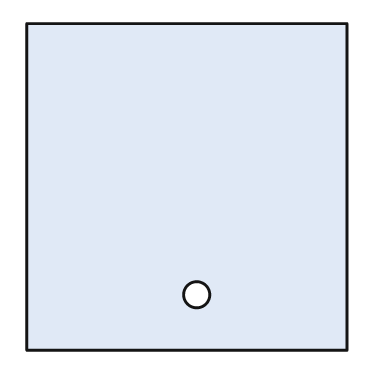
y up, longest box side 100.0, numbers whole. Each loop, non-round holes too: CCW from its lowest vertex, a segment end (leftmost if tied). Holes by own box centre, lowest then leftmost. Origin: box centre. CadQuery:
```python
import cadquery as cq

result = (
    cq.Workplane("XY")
    .moveTo(-49.0, -50.0)
    .lineTo(49.0, -50.0)
    .lineTo(49.0, 50.0)
    .lineTo(-49.0, 50.0)
    .close()
    .moveTo(3.0, -33.0)
    .circle(4.0)
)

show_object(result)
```